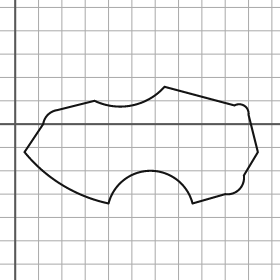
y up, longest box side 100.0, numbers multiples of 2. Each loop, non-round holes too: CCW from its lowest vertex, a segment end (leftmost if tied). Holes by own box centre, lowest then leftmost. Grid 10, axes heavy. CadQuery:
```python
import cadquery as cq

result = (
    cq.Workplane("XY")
    .moveTo(40.0, -34.0)
    .threePointArc((58.0, -20.0), (76.0, -34.0))
    .lineTo(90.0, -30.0)
    .threePointArc((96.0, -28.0), (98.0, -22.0))
    .lineTo(104.0, -12.0)
    .lineTo(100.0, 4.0)
    .threePointArc((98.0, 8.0), (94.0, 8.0))
    .lineTo(64.0, 16.0)
    .threePointArc((50.0, 8.0), (34.0, 10.0))
    .lineTo(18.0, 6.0)
    .threePointArc((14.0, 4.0), (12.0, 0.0))
    .lineTo(4.0, -12.0)
    .threePointArc((20.0, -26.0), (40.0, -34.0))
    .close()
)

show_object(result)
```